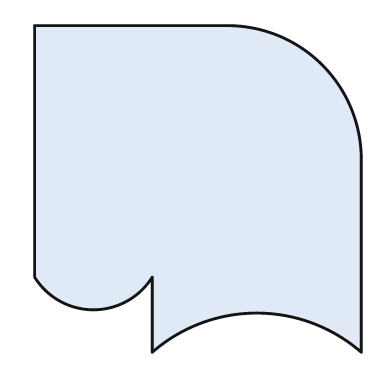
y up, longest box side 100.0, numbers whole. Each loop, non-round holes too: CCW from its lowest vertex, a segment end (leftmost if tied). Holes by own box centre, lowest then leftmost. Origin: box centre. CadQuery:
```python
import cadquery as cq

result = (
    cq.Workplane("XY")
    .moveTo(-14.0, -50.0)
    .threePointArc((18.0, -38.0), (50.0, -50.0))
    .lineTo(50.0, 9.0)
    .threePointArc((38.0, 38.0), (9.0, 50.0))
    .lineTo(-50.0, 50.0)
    .lineTo(-50.0, -27.0)
    .threePointArc((-32.0, -37.0), (-14.0, -27.0))
    .close()
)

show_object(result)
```